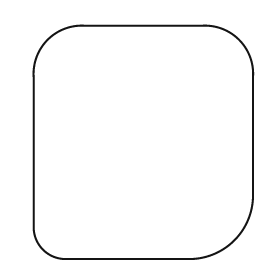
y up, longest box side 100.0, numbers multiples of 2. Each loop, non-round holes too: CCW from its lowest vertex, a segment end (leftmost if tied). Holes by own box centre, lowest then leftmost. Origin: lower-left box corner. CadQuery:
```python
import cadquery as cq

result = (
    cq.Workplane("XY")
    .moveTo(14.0, 0.0)
    .lineTo(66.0, 0.0)
    .threePointArc((86.0, 8.0), (94.0, 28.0))
    .lineTo(94.0, 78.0)
    .threePointArc((88.0, 94.0), (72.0, 100.0))
    .lineTo(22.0, 100.0)
    .threePointArc((6.0, 94.0), (0.0, 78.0))
    .lineTo(0.0, 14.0)
    .threePointArc((4.0, 4.0), (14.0, 0.0))
    .close()
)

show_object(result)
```